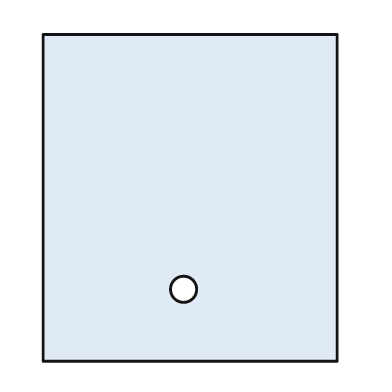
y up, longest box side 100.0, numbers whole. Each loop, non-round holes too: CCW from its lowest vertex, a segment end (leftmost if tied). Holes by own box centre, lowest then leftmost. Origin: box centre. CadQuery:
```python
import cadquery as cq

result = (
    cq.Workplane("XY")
    .moveTo(-45.0, -50.0)
    .lineTo(45.0, -50.0)
    .lineTo(45.0, 50.0)
    .lineTo(-45.0, 50.0)
    .close()
    .moveTo(-2.0, -28.0)
    .circle(4.0)
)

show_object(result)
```